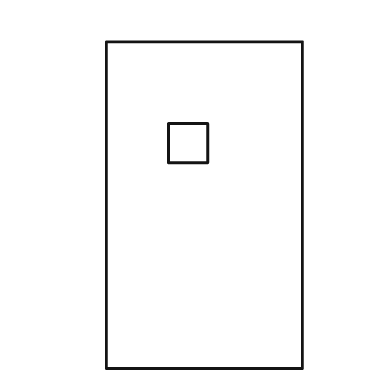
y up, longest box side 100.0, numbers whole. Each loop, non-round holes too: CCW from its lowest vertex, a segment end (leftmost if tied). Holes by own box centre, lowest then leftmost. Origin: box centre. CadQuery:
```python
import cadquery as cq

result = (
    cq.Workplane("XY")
    .moveTo(-30.0, -50.0)
    .lineTo(30.0, -50.0)
    .lineTo(30.0, 50.0)
    .lineTo(-30.0, 50.0)
    .close()
    .moveTo(-11.0, 13.0)
    .lineTo(1.0, 13.0)
    .lineTo(1.0, 25.0)
    .lineTo(-11.0, 25.0)
    .close()
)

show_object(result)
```